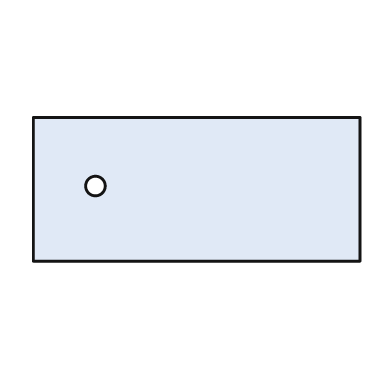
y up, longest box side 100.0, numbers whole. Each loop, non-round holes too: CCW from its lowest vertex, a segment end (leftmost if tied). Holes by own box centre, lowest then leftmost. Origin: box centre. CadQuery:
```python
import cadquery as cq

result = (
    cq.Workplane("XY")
    .moveTo(-50.0, -22.0)
    .lineTo(50.0, -22.0)
    .lineTo(50.0, 22.0)
    .lineTo(-50.0, 22.0)
    .close()
    .moveTo(-31.0, 1.0)
    .circle(3.0)
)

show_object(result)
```